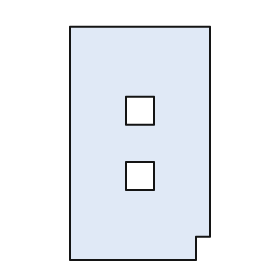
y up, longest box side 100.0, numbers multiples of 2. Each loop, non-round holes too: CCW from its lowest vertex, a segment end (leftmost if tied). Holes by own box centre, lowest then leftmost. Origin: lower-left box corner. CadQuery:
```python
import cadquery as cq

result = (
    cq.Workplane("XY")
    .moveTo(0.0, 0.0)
    .lineTo(54.0, 0.0)
    .lineTo(54.0, 10.0)
    .lineTo(60.0, 10.0)
    .lineTo(60.0, 100.0)
    .lineTo(0.0, 100.0)
    .close()
    .moveTo(24.0, 30.0)
    .lineTo(36.0, 30.0)
    .lineTo(36.0, 42.0)
    .lineTo(24.0, 42.0)
    .close()
    .moveTo(24.0, 58.0)
    .lineTo(36.0, 58.0)
    .lineTo(36.0, 70.0)
    .lineTo(24.0, 70.0)
    .close()
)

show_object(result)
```